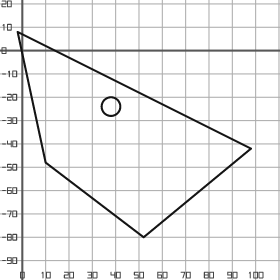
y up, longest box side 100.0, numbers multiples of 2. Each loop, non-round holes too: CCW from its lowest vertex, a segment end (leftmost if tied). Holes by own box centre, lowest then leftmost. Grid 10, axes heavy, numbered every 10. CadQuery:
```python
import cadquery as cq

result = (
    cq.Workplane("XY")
    .moveTo(52.0, -80.0)
    .lineTo(98.0, -42.0)
    .lineTo(-2.0, 8.0)
    .lineTo(10.0, -48.0)
    .close()
    .moveTo(38.0, -24.0)
    .circle(4.0)
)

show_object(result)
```